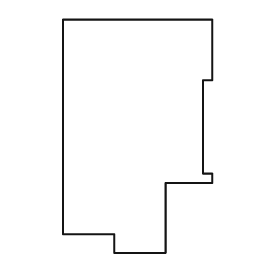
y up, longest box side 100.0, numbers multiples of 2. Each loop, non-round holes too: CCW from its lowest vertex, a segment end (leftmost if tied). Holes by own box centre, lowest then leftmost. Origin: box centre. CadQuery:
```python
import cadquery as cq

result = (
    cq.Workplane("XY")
    .moveTo(-10.0, -50.0)
    .lineTo(12.0, -50.0)
    .lineTo(12.0, -20.0)
    .lineTo(32.0, -20.0)
    .lineTo(32.0, -16.0)
    .lineTo(28.0, -16.0)
    .lineTo(28.0, 24.0)
    .lineTo(32.0, 24.0)
    .lineTo(32.0, 50.0)
    .lineTo(-32.0, 50.0)
    .lineTo(-32.0, -42.0)
    .lineTo(-10.0, -42.0)
    .close()
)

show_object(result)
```